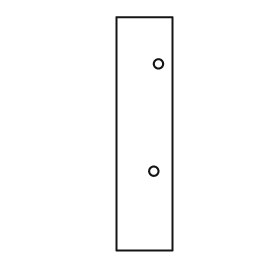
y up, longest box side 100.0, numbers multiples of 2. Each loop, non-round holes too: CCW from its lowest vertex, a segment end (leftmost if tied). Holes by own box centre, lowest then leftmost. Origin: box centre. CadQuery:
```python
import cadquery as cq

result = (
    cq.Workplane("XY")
    .moveTo(-12.0, -50.0)
    .lineTo(12.0, -50.0)
    .lineTo(12.0, 50.0)
    .lineTo(-12.0, 50.0)
    .close()
    .moveTo(4.0, -16.0)
    .circle(2.0)
    .moveTo(6.0, 30.0)
    .circle(2.0)
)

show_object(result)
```